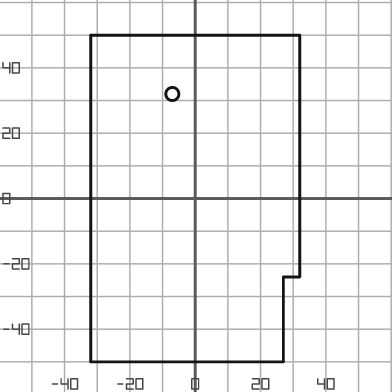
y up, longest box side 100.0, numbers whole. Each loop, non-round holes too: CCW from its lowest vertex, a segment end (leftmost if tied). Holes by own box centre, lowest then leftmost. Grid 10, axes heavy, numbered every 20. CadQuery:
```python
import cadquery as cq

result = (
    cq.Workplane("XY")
    .moveTo(-32.0, -50.0)
    .lineTo(27.0, -50.0)
    .lineTo(27.0, -24.0)
    .lineTo(32.0, -24.0)
    .lineTo(32.0, 50.0)
    .lineTo(-32.0, 50.0)
    .close()
    .moveTo(-7.0, 32.0)
    .circle(2.0)
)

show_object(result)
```